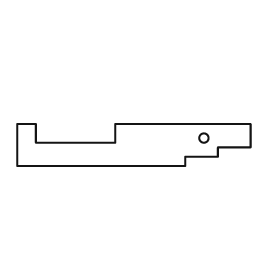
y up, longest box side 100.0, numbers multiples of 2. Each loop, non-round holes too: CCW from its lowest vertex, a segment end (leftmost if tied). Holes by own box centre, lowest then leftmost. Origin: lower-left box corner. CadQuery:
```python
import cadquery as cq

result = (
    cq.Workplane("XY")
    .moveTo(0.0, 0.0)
    .lineTo(72.0, 0.0)
    .lineTo(72.0, 4.0)
    .lineTo(86.0, 4.0)
    .lineTo(86.0, 8.0)
    .lineTo(100.0, 8.0)
    .lineTo(100.0, 18.0)
    .lineTo(42.0, 18.0)
    .lineTo(42.0, 10.0)
    .lineTo(8.0, 10.0)
    .lineTo(8.0, 18.0)
    .lineTo(0.0, 18.0)
    .close()
    .moveTo(80.0, 12.0)
    .circle(2.0)
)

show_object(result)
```